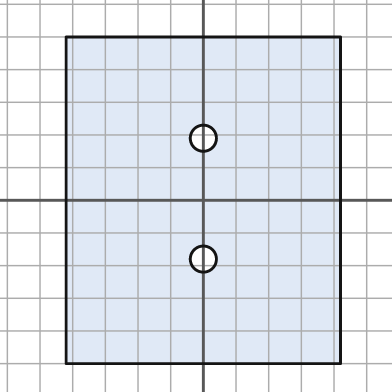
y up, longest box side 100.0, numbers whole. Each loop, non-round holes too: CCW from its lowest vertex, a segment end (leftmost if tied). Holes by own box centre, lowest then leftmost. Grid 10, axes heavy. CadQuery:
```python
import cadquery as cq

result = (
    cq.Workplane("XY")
    .moveTo(-42.0, -50.0)
    .lineTo(42.0, -50.0)
    .lineTo(42.0, 50.0)
    .lineTo(-42.0, 50.0)
    .close()
    .moveTo(0.0, -18.0)
    .circle(4.0)
    .moveTo(0.0, 19.0)
    .circle(4.0)
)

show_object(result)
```